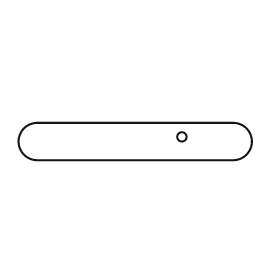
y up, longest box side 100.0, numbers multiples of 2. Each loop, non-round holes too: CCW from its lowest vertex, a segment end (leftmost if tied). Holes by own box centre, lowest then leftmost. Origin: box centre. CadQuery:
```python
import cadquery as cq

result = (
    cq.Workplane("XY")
    .moveTo(-42.0, -8.0)
    .lineTo(42.0, -8.0)
    .threePointArc((50.0, 0.0), (42.0, 8.0))
    .lineTo(-42.0, 8.0)
    .threePointArc((-50.0, 0.0), (-42.0, -8.0))
    .close()
    .moveTo(20.0, 2.0)
    .circle(2.0)
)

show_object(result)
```